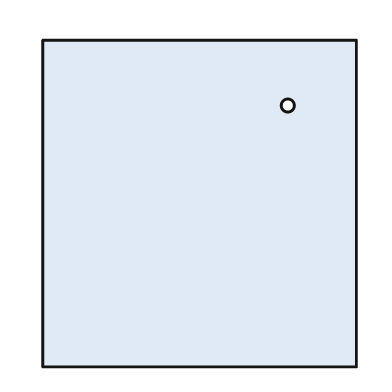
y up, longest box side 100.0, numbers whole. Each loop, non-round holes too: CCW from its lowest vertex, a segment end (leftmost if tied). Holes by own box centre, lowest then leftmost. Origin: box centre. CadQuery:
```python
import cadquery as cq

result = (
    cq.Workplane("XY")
    .moveTo(-48.0, -50.0)
    .lineTo(48.0, -50.0)
    .lineTo(48.0, 50.0)
    .lineTo(-48.0, 50.0)
    .close()
    .moveTo(27.0, 30.0)
    .circle(2.0)
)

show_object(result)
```